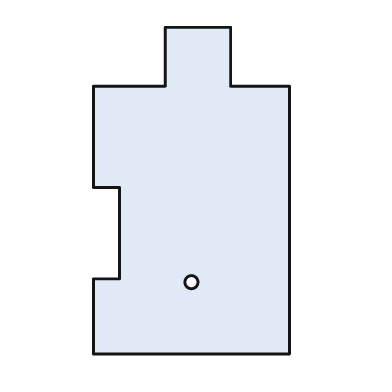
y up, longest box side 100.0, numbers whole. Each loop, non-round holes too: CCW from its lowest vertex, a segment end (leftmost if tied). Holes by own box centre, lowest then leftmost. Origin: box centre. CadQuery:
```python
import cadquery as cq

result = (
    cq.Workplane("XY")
    .moveTo(-30.0, -50.0)
    .lineTo(30.0, -50.0)
    .lineTo(30.0, 32.0)
    .lineTo(12.0, 32.0)
    .lineTo(12.0, 50.0)
    .lineTo(-8.0, 50.0)
    .lineTo(-8.0, 32.0)
    .lineTo(-30.0, 32.0)
    .lineTo(-30.0, 1.0)
    .lineTo(-22.0, 1.0)
    .lineTo(-22.0, -27.0)
    .lineTo(-30.0, -27.0)
    .close()
    .moveTo(0.0, -28.0)
    .circle(2.0)
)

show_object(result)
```